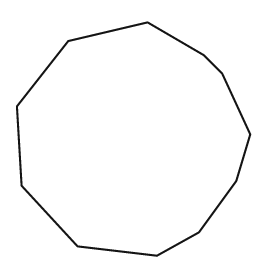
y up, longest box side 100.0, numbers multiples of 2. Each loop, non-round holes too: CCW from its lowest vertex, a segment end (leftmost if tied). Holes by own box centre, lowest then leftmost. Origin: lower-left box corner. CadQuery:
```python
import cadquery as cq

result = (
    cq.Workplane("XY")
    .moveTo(60.0, 0.0)
    .lineTo(78.0, 10.0)
    .lineTo(94.0, 32.0)
    .lineTo(100.0, 52.0)
    .lineTo(88.0, 78.0)
    .lineTo(80.0, 86.0)
    .lineTo(56.0, 100.0)
    .lineTo(22.0, 92.0)
    .lineTo(0.0, 64.0)
    .lineTo(2.0, 30.0)
    .lineTo(26.0, 4.0)
    .close()
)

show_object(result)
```